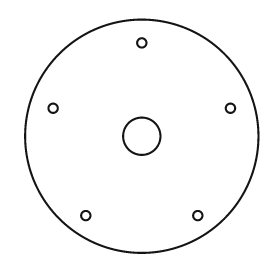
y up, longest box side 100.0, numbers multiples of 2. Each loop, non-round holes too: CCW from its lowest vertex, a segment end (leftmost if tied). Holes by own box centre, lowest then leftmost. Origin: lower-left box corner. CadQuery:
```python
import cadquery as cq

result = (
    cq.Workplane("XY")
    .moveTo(50.0, 50.0)
    .circle(50.0)
    .moveTo(26.0, 16.0)
    .circle(2.0)
    .moveTo(74.0, 16.0)
    .circle(2.0)
    .moveTo(50.0, 50.0)
    .circle(8.0)
    .moveTo(12.0, 62.0)
    .circle(2.0)
    .moveTo(88.0, 62.0)
    .circle(2.0)
    .moveTo(50.0, 90.0)
    .circle(2.0)
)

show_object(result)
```